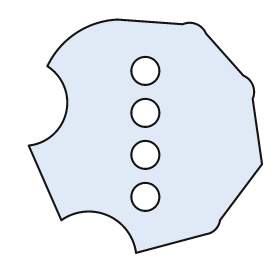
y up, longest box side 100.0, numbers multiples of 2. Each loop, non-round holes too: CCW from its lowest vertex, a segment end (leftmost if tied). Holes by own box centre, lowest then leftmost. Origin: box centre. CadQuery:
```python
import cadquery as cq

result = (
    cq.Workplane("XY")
    .moveTo(-4.0, -50.0)
    .lineTo(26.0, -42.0)
    .threePointArc((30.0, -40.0), (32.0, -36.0))
    .lineTo(50.0, -12.0)
    .lineTo(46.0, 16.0)
    .threePointArc((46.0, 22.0), (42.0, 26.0))
    .lineTo(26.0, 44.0)
    .threePointArc((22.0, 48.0), (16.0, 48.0))
    .lineTo(-12.0, 50.0)
    .threePointArc((-30.0, 44.0), (-42.0, 30.0))
    .threePointArc((-34.0, 10.0), (-50.0, -4.0))
    .lineTo(-36.0, -36.0)
    .threePointArc((-16.0, -34.0), (-4.0, -50.0))
    .close()
    .moveTo(0.0, -26.0)
    .circle(6.0)
    .moveTo(0.0, -8.0)
    .circle(6.0)
    .moveTo(0.0, 10.0)
    .circle(6.0)
    .moveTo(0.0, 28.0)
    .circle(6.0)
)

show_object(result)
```